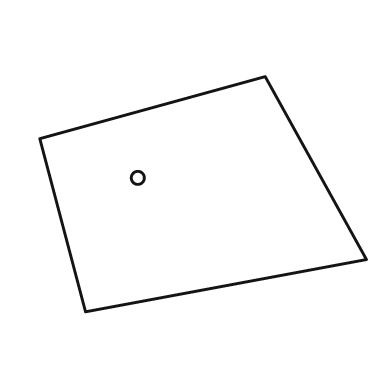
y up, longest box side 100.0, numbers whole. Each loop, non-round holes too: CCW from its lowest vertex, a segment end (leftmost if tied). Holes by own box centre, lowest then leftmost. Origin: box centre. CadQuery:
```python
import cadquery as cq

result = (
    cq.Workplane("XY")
    .moveTo(-36.0, -36.0)
    .lineTo(50.0, -20.0)
    .lineTo(19.0, 36.0)
    .lineTo(-50.0, 17.0)
    .close()
    .moveTo(-20.0, 5.0)
    .circle(2.0)
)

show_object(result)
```